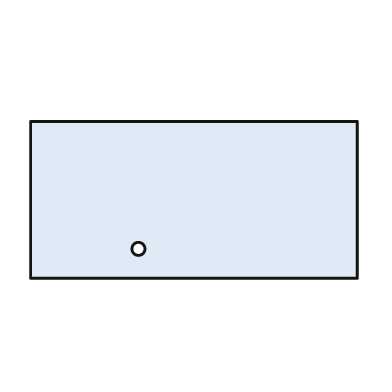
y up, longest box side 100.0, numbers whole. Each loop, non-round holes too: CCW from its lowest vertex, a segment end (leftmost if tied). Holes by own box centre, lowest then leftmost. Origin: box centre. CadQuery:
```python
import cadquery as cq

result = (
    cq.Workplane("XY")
    .moveTo(-50.0, -24.0)
    .lineTo(50.0, -24.0)
    .lineTo(50.0, 24.0)
    .lineTo(-50.0, 24.0)
    .close()
    .moveTo(-17.0, -15.0)
    .circle(2.0)
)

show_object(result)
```